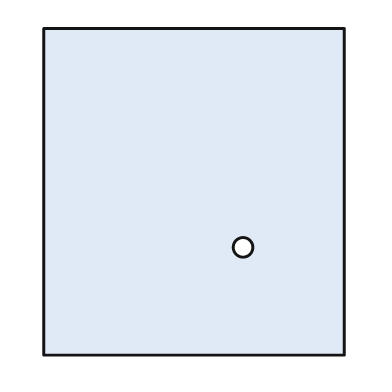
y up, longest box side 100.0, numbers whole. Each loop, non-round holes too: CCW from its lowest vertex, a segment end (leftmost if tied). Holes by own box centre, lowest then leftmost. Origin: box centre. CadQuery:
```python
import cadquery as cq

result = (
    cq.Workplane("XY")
    .moveTo(-46.0, -50.0)
    .lineTo(46.0, -50.0)
    .lineTo(46.0, 50.0)
    .lineTo(-46.0, 50.0)
    .close()
    .moveTo(15.0, -17.0)
    .circle(3.0)
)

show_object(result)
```